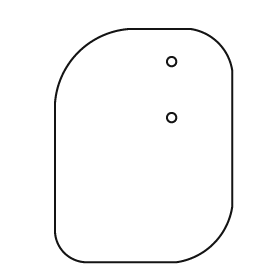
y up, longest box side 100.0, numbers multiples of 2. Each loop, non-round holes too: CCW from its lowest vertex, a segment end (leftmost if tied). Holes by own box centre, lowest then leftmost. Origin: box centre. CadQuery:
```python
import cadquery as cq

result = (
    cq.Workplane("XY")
    .moveTo(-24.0, -50.0)
    .lineTo(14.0, -50.0)
    .threePointArc((30.0, -42.0), (38.0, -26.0))
    .lineTo(38.0, 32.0)
    .threePointArc((32.0, 44.0), (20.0, 50.0))
    .lineTo(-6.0, 50.0)
    .threePointArc((-28.0, 40.0), (-38.0, 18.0))
    .lineTo(-38.0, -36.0)
    .threePointArc((-34.0, -46.0), (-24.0, -50.0))
    .close()
    .moveTo(12.0, 12.0)
    .circle(2.0)
    .moveTo(12.0, 36.0)
    .circle(2.0)
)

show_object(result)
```